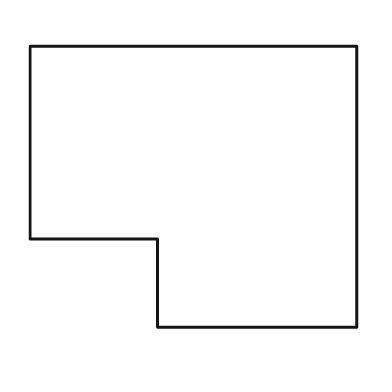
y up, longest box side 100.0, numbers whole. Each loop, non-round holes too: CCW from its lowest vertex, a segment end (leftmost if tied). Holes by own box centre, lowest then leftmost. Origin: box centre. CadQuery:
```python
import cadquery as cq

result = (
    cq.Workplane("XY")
    .moveTo(-11.0, -43.0)
    .lineTo(50.0, -43.0)
    .lineTo(50.0, 43.0)
    .lineTo(-50.0, 43.0)
    .lineTo(-50.0, -16.0)
    .lineTo(-11.0, -16.0)
    .close()
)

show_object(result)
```